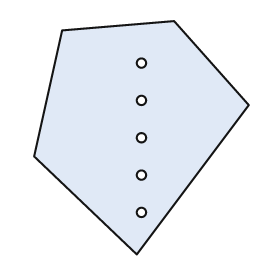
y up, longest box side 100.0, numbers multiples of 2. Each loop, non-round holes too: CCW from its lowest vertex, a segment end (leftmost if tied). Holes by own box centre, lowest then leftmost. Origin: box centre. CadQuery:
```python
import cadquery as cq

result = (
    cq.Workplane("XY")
    .moveTo(-2.0, -50.0)
    .lineTo(46.0, 14.0)
    .lineTo(14.0, 50.0)
    .lineTo(-34.0, 46.0)
    .lineTo(-46.0, -8.0)
    .close()
    .moveTo(0.0, -32.0)
    .circle(2.0)
    .moveTo(0.0, -16.0)
    .circle(2.0)
    .moveTo(0.0, 0.0)
    .circle(2.0)
    .moveTo(0.0, 16.0)
    .circle(2.0)
    .moveTo(0.0, 32.0)
    .circle(2.0)
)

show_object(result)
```